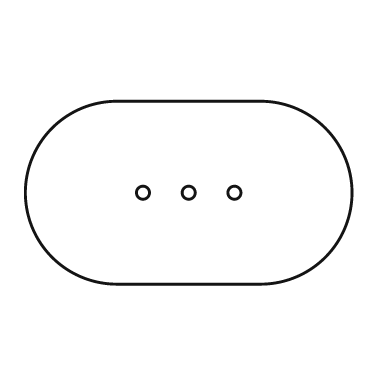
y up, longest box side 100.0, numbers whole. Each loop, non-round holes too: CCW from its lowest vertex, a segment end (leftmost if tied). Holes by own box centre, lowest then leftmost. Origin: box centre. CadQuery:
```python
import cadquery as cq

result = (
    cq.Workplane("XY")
    .moveTo(-22.0, -28.0)
    .lineTo(22.0, -28.0)
    .threePointArc((50.0, 0.0), (22.0, 28.0))
    .lineTo(-22.0, 28.0)
    .threePointArc((-50.0, 0.0), (-22.0, -28.0))
    .close()
    .moveTo(-14.0, 0.0)
    .circle(2.0)
    .moveTo(0.0, 0.0)
    .circle(2.0)
    .moveTo(14.0, 0.0)
    .circle(2.0)
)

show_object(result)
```